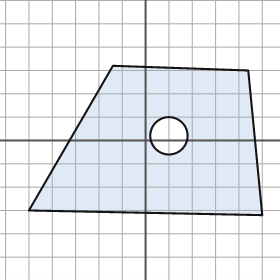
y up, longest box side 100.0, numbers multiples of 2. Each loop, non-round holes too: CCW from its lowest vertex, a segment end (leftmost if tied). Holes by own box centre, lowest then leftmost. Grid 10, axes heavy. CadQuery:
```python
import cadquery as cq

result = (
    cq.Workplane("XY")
    .moveTo(50.0, -32.0)
    .lineTo(44.0, 30.0)
    .lineTo(-14.0, 32.0)
    .lineTo(-50.0, -30.0)
    .close()
    .moveTo(10.0, 2.0)
    .circle(8.0)
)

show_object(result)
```